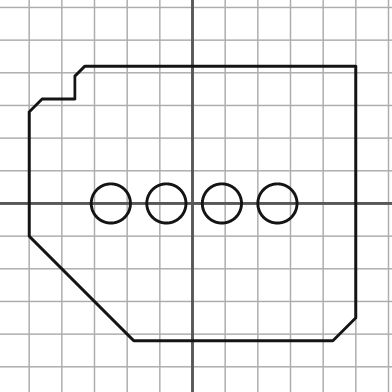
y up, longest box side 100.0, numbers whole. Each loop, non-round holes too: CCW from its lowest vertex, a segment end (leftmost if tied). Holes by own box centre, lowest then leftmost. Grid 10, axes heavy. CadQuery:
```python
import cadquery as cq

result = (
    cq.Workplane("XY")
    .moveTo(-18.0, -42.0)
    .lineTo(43.0, -42.0)
    .lineTo(50.0, -35.0)
    .lineTo(50.0, 42.0)
    .lineTo(-33.0, 42.0)
    .lineTo(-36.0, 39.0)
    .lineTo(-36.0, 32.0)
    .lineTo(-46.0, 32.0)
    .lineTo(-50.0, 28.0)
    .lineTo(-50.0, -10.0)
    .close()
    .moveTo(-25.0, 0.0)
    .circle(6.0)
    .moveTo(-8.0, 0.0)
    .circle(6.0)
    .moveTo(9.0, 0.0)
    .circle(6.0)
    .moveTo(26.0, 0.0)
    .circle(6.0)
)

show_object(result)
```